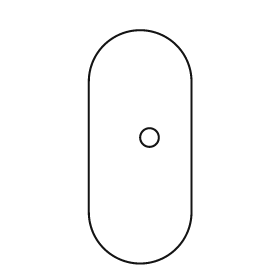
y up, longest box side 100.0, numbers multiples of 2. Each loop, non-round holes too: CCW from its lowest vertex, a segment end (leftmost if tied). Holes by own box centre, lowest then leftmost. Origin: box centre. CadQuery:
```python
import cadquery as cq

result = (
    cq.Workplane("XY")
    .moveTo(-22.0, -28.0)
    .threePointArc((0.0, -50.0), (22.0, -28.0))
    .lineTo(22.0, 28.0)
    .threePointArc((0.0, 50.0), (-22.0, 28.0))
    .close()
    .moveTo(4.0, 4.0)
    .circle(4.0)
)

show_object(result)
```